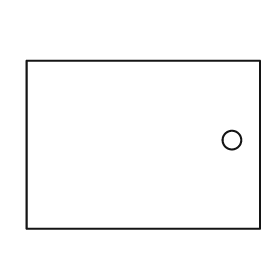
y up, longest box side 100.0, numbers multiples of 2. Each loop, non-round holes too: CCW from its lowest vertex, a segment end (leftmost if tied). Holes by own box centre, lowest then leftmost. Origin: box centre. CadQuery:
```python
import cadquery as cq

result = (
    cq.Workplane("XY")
    .moveTo(-50.0, -36.0)
    .lineTo(50.0, -36.0)
    .lineTo(50.0, 36.0)
    .lineTo(-50.0, 36.0)
    .close()
    .moveTo(38.0, 2.0)
    .circle(4.0)
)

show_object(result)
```